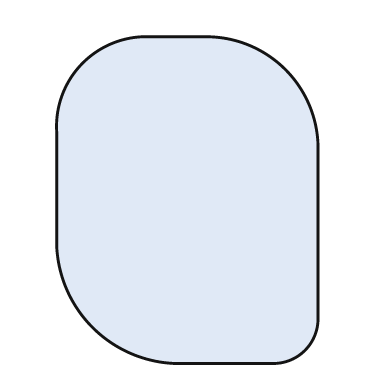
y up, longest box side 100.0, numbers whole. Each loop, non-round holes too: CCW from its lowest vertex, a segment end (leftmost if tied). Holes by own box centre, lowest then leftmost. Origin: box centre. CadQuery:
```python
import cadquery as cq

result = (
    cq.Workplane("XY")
    .moveTo(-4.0, -50.0)
    .lineTo(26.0, -50.0)
    .threePointArc((36.0, -46.0), (40.0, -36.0))
    .lineTo(40.0, 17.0)
    .threePointArc((30.0, 40.0), (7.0, 50.0))
    .lineTo(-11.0, 50.0)
    .threePointArc((-32.0, 42.0), (-40.0, 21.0))
    .lineTo(-40.0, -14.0)
    .threePointArc((-29.0, -39.0), (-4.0, -50.0))
    .close()
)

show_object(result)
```